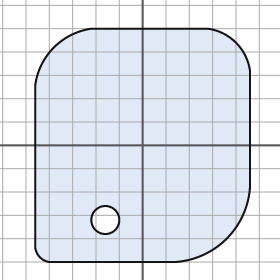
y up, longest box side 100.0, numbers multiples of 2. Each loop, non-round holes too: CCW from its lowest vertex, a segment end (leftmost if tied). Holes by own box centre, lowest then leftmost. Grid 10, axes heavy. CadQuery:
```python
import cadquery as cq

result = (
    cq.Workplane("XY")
    .moveTo(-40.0, -50.0)
    .lineTo(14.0, -50.0)
    .threePointArc((36.0, -40.0), (46.0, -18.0))
    .lineTo(46.0, 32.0)
    .threePointArc((40.0, 44.0), (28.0, 50.0))
    .lineTo(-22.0, 50.0)
    .threePointArc((-38.0, 42.0), (-46.0, 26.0))
    .lineTo(-46.0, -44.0)
    .threePointArc((-44.0, -48.0), (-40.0, -50.0))
    .close()
    .moveTo(-16.0, -32.0)
    .circle(6.0)
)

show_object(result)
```